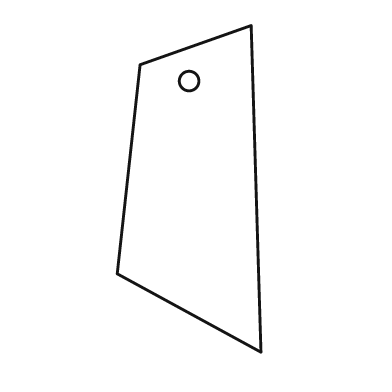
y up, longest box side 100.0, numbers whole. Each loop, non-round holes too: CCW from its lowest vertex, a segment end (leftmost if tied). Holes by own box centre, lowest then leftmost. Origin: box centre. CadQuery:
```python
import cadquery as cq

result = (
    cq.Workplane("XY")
    .moveTo(22.0, -50.0)
    .lineTo(19.0, 50.0)
    .lineTo(-15.0, 38.0)
    .lineTo(-22.0, -26.0)
    .close()
    .moveTo(0.0, 33.0)
    .circle(3.0)
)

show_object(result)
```